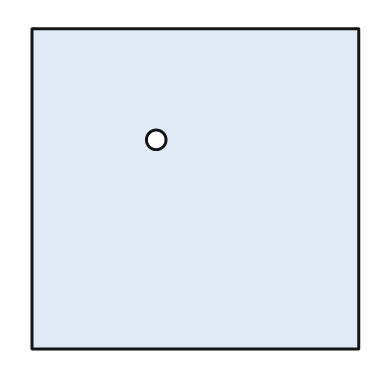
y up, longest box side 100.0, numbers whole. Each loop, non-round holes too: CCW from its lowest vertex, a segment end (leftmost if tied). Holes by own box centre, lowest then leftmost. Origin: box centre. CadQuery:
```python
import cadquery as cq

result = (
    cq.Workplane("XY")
    .moveTo(-50.0, -49.0)
    .lineTo(50.0, -49.0)
    .lineTo(50.0, 49.0)
    .lineTo(-50.0, 49.0)
    .close()
    .moveTo(-12.0, 15.0)
    .circle(3.0)
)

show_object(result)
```